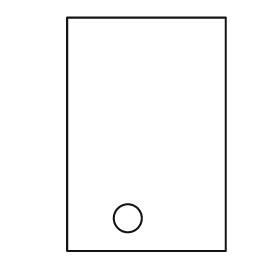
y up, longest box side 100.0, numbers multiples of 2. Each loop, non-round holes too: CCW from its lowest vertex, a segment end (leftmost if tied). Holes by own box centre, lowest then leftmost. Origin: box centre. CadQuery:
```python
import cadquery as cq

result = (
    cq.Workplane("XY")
    .moveTo(-34.0, -50.0)
    .lineTo(34.0, -50.0)
    .lineTo(34.0, 50.0)
    .lineTo(-34.0, 50.0)
    .close()
    .moveTo(-8.0, -36.0)
    .circle(6.0)
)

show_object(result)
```